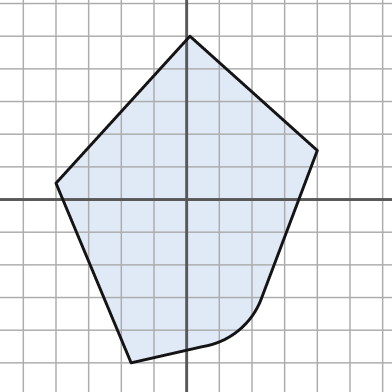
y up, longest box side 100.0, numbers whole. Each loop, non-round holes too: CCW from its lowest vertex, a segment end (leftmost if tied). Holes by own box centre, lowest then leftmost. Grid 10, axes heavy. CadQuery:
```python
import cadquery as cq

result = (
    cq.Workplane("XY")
    .moveTo(-17.0, -50.0)
    .lineTo(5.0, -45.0)
    .threePointArc((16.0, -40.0), (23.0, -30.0))
    .lineTo(40.0, 15.0)
    .lineTo(1.0, 50.0)
    .lineTo(-40.0, 5.0)
    .close()
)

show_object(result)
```